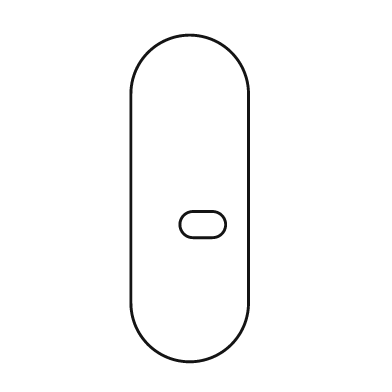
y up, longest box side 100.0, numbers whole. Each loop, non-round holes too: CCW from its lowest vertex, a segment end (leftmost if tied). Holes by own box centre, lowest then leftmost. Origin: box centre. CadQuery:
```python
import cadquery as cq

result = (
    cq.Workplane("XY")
    .moveTo(-18.0, -32.0)
    .threePointArc((0.0, -50.0), (18.0, -32.0))
    .lineTo(18.0, 32.0)
    .threePointArc((0.0, 50.0), (-18.0, 32.0))
    .close()
    .moveTo(1.0, -12.0)
    .lineTo(7.0, -12.0)
    .threePointArc((11.0, -8.0), (7.0, -4.0))
    .lineTo(1.0, -4.0)
    .threePointArc((-3.0, -8.0), (1.0, -12.0))
    .close()
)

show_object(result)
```